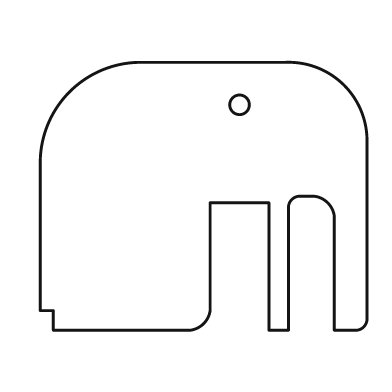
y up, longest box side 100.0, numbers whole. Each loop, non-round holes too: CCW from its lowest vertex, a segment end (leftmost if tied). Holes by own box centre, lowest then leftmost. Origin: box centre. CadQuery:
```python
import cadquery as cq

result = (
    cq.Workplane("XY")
    .moveTo(-46.0, -41.0)
    .lineTo(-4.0, -41.0)
    .threePointArc((0.0, -39.0), (2.0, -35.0))
    .lineTo(2.0, -2.0)
    .lineTo(20.0, -2.0)
    .lineTo(20.0, -41.0)
    .lineTo(26.0, -41.0)
    .lineTo(26.0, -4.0)
    .threePointArc((27.0, -1.0), (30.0, 0.0))
    .lineTo(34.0, 0.0)
    .threePointArc((38.0, -2.0), (40.0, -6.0))
    .lineTo(40.0, -41.0)
    .lineTo(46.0, -41.0)
    .threePointArc((49.0, -40.0), (50.0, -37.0))
    .lineTo(50.0, 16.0)
    .threePointArc((43.0, 34.0), (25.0, 41.0))
    .lineTo(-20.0, 41.0)
    .threePointArc((-41.0, 32.0), (-50.0, 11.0))
    .lineTo(-50.0, -35.0)
    .lineTo(-46.0, -35.0)
    .close()
    .moveTo(11.0, 28.0)
    .circle(3.0)
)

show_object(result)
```